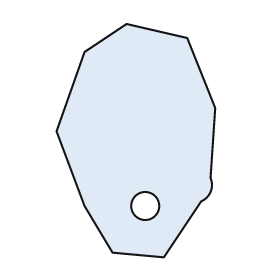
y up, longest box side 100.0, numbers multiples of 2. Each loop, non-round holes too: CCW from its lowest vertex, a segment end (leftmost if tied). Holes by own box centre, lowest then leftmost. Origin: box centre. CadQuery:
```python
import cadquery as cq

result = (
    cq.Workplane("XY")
    .moveTo(12.0, -50.0)
    .lineTo(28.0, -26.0)
    .threePointArc((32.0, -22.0), (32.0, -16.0))
    .lineTo(34.0, 14.0)
    .lineTo(22.0, 44.0)
    .lineTo(-4.0, 50.0)
    .lineTo(-22.0, 38.0)
    .lineTo(-34.0, 4.0)
    .lineTo(-22.0, -28.0)
    .lineTo(-10.0, -48.0)
    .close()
    .moveTo(4.0, -28.0)
    .circle(6.0)
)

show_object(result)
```